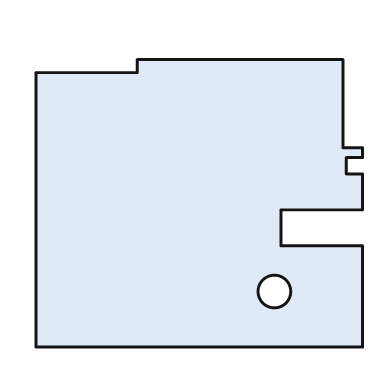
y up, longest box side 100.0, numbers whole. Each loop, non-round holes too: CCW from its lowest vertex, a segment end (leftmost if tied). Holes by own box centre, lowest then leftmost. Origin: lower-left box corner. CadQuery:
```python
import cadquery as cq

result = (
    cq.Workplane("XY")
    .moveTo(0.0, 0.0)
    .lineTo(100.0, 0.0)
    .lineTo(100.0, 31.0)
    .lineTo(75.0, 31.0)
    .lineTo(75.0, 42.0)
    .lineTo(100.0, 42.0)
    .lineTo(100.0, 53.0)
    .lineTo(95.0, 53.0)
    .lineTo(95.0, 58.0)
    .lineTo(100.0, 58.0)
    .lineTo(100.0, 61.0)
    .lineTo(94.0, 61.0)
    .lineTo(94.0, 88.0)
    .lineTo(31.0, 88.0)
    .lineTo(31.0, 84.0)
    .lineTo(0.0, 84.0)
    .close()
    .moveTo(73.0, 17.0)
    .circle(5.0)
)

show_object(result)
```